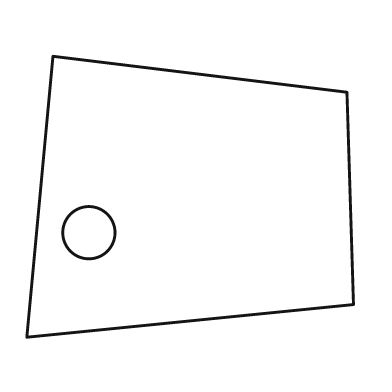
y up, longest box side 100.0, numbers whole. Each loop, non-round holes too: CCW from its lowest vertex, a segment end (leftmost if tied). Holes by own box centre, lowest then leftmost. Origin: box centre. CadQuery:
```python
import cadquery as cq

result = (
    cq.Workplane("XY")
    .moveTo(-50.0, -43.0)
    .lineTo(50.0, -33.0)
    .lineTo(48.0, 32.0)
    .lineTo(-42.0, 43.0)
    .close()
    .moveTo(-31.0, -11.0)
    .circle(8.0)
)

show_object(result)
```